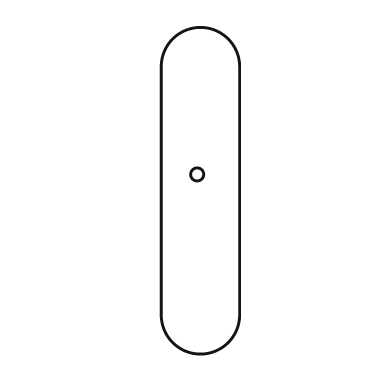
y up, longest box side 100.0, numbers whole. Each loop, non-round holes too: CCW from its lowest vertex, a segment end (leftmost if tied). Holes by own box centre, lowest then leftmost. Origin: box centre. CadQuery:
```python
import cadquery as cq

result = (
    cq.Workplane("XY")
    .moveTo(-12.0, -38.0)
    .threePointArc((0.0, -50.0), (12.0, -38.0))
    .lineTo(12.0, 38.0)
    .threePointArc((0.0, 50.0), (-12.0, 38.0))
    .close()
    .moveTo(-1.0, 5.0)
    .circle(2.0)
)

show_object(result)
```